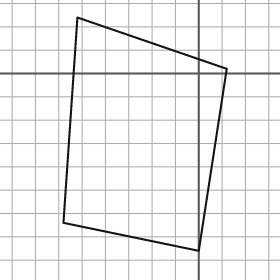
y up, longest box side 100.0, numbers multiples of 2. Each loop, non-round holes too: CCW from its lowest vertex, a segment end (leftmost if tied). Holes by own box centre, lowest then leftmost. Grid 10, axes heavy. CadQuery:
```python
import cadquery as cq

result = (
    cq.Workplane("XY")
    .moveTo(0.0, -76.0)
    .lineTo(12.0, 2.0)
    .lineTo(-52.0, 24.0)
    .lineTo(-58.0, -64.0)
    .close()
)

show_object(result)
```